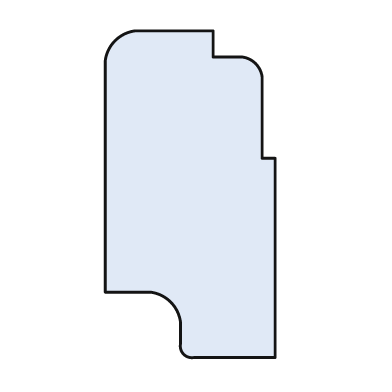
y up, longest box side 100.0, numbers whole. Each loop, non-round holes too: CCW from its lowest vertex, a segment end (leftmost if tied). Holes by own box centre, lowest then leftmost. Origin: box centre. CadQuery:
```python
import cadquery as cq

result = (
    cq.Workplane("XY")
    .moveTo(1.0, -50.0)
    .lineTo(26.0, -50.0)
    .lineTo(26.0, 11.0)
    .lineTo(22.0, 11.0)
    .lineTo(22.0, 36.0)
    .threePointArc((20.0, 40.0), (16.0, 42.0))
    .lineTo(7.0, 42.0)
    .lineTo(7.0, 50.0)
    .lineTo(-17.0, 50.0)
    .threePointArc((-23.0, 47.0), (-26.0, 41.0))
    .lineTo(-26.0, -30.0)
    .lineTo(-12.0, -30.0)
    .threePointArc((-6.0, -33.0), (-3.0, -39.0))
    .lineTo(-3.0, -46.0)
    .threePointArc((-2.0, -49.0), (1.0, -50.0))
    .close()
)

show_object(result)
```